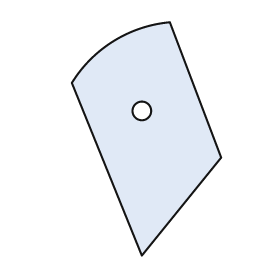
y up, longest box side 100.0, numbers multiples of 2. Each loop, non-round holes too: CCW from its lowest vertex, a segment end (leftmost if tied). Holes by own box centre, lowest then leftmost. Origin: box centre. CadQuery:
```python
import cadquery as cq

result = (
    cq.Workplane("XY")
    .moveTo(-2.0, -50.0)
    .lineTo(32.0, -8.0)
    .lineTo(10.0, 50.0)
    .threePointArc((-14.0, 42.0), (-32.0, 24.0))
    .close()
    .moveTo(-2.0, 12.0)
    .circle(4.0)
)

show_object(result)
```